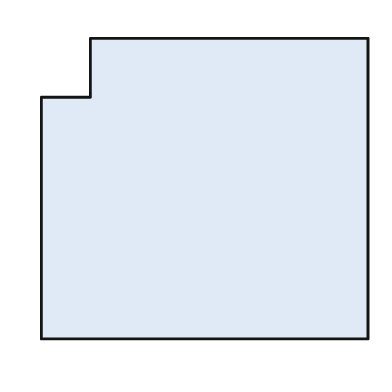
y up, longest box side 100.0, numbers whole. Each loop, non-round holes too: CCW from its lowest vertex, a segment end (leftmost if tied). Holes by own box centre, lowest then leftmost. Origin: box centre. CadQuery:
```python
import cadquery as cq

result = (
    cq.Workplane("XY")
    .moveTo(-50.0, -46.0)
    .lineTo(50.0, -46.0)
    .lineTo(50.0, 46.0)
    .lineTo(-35.0, 46.0)
    .lineTo(-35.0, 28.0)
    .lineTo(-50.0, 28.0)
    .close()
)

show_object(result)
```